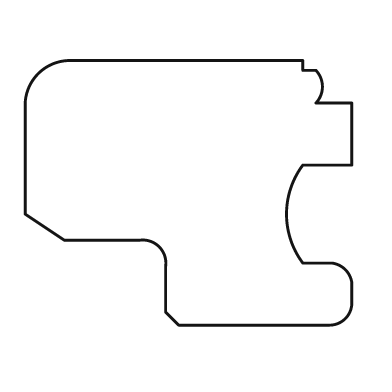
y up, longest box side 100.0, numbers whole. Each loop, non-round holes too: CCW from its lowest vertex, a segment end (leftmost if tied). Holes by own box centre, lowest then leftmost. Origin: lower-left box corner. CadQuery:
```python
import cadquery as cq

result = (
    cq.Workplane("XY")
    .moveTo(47.0, 0.0)
    .lineTo(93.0, 0.0)
    .threePointArc((98.0, 2.0), (100.0, 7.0))
    .lineTo(100.0, 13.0)
    .threePointArc((98.0, 17.0), (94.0, 19.0))
    .lineTo(85.0, 19.0)
    .threePointArc((80.0, 34.0), (85.0, 49.0))
    .lineTo(100.0, 49.0)
    .lineTo(100.0, 68.0)
    .lineTo(89.0, 68.0)
    .threePointArc((91.0, 73.0), (89.0, 78.0))
    .lineTo(85.0, 78.0)
    .lineTo(85.0, 81.0)
    .lineTo(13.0, 81.0)
    .threePointArc((4.0, 77.0), (0.0, 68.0))
    .lineTo(0.0, 34.0)
    .lineTo(12.0, 26.0)
    .lineTo(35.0, 26.0)
    .threePointArc((41.0, 24.0), (43.0, 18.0))
    .lineTo(43.0, 4.0)
    .close()
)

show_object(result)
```